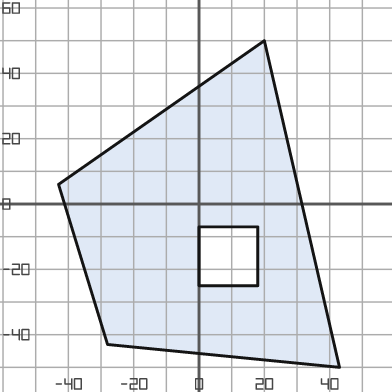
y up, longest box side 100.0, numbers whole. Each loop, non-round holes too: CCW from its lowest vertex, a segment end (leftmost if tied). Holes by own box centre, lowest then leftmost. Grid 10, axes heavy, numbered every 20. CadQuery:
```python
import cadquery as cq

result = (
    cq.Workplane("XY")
    .moveTo(43.0, -50.0)
    .lineTo(20.0, 50.0)
    .lineTo(-43.0, 6.0)
    .lineTo(-28.0, -43.0)
    .close()
    .moveTo(0.0, -25.0)
    .lineTo(18.0, -25.0)
    .lineTo(18.0, -7.0)
    .lineTo(0.0, -7.0)
    .close()
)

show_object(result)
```